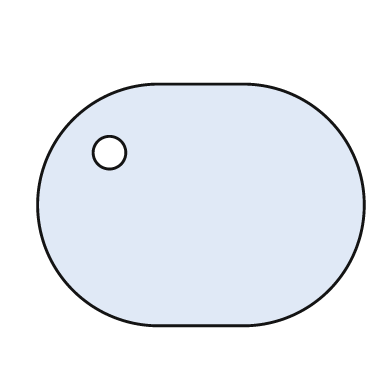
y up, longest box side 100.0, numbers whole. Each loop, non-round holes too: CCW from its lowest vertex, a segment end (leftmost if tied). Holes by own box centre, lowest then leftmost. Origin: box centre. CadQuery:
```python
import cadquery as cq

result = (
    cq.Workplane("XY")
    .moveTo(-13.0, -37.0)
    .lineTo(13.0, -37.0)
    .threePointArc((50.0, 0.0), (13.0, 37.0))
    .lineTo(-13.0, 37.0)
    .threePointArc((-50.0, 0.0), (-13.0, -37.0))
    .close()
    .moveTo(-28.0, 16.0)
    .circle(5.0)
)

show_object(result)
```